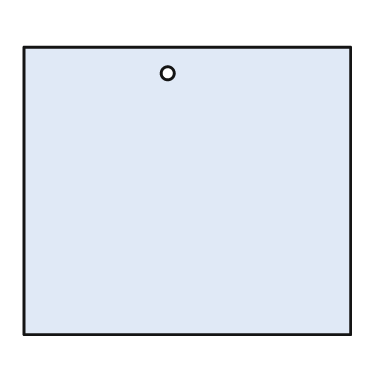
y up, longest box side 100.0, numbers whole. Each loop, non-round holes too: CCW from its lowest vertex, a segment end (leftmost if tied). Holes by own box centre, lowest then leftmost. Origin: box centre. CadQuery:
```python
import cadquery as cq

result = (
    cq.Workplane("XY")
    .moveTo(-50.0, -44.0)
    .lineTo(50.0, -44.0)
    .lineTo(50.0, 44.0)
    .lineTo(-50.0, 44.0)
    .close()
    .moveTo(-6.0, 36.0)
    .circle(2.0)
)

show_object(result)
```